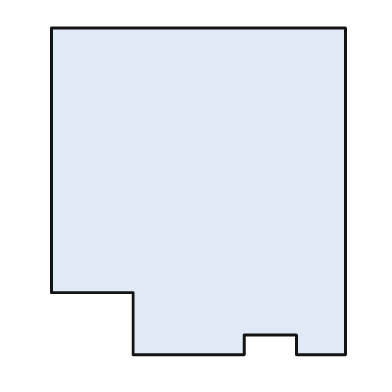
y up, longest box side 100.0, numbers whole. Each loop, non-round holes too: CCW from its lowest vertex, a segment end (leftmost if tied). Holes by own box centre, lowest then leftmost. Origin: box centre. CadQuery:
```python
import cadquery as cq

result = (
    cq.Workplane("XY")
    .moveTo(-20.0, -50.0)
    .lineTo(14.0, -50.0)
    .lineTo(14.0, -44.0)
    .lineTo(30.0, -44.0)
    .lineTo(30.0, -50.0)
    .lineTo(45.0, -50.0)
    .lineTo(45.0, 50.0)
    .lineTo(-45.0, 50.0)
    .lineTo(-45.0, -31.0)
    .lineTo(-20.0, -31.0)
    .close()
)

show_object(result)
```